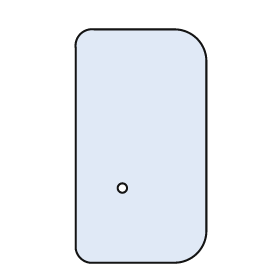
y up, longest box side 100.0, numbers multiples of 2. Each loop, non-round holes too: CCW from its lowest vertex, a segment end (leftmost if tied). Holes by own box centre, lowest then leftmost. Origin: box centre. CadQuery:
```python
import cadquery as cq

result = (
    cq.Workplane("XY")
    .moveTo(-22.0, -50.0)
    .lineTo(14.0, -50.0)
    .threePointArc((24.0, -46.0), (28.0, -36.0))
    .lineTo(28.0, 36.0)
    .threePointArc((24.0, 46.0), (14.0, 50.0))
    .lineTo(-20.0, 50.0)
    .threePointArc((-26.0, 48.0), (-28.0, 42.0))
    .lineTo(-28.0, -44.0)
    .threePointArc((-26.0, -48.0), (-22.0, -50.0))
    .close()
    .moveTo(-8.0, -18.0)
    .circle(2.0)
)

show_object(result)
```